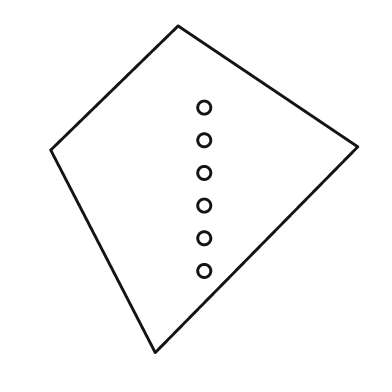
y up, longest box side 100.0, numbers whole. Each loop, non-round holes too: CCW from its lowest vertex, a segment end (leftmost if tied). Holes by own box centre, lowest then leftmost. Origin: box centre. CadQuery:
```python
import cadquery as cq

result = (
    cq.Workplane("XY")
    .moveTo(-15.0, -50.0)
    .lineTo(47.0, 13.0)
    .lineTo(-8.0, 50.0)
    .lineTo(-47.0, 12.0)
    .close()
    .moveTo(0.0, -25.0)
    .circle(2.0)
    .moveTo(0.0, -15.0)
    .circle(2.0)
    .moveTo(0.0, -5.0)
    .circle(2.0)
    .moveTo(0.0, 5.0)
    .circle(2.0)
    .moveTo(0.0, 15.0)
    .circle(2.0)
    .moveTo(0.0, 25.0)
    .circle(2.0)
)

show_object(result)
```